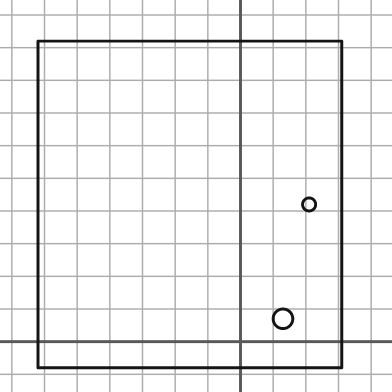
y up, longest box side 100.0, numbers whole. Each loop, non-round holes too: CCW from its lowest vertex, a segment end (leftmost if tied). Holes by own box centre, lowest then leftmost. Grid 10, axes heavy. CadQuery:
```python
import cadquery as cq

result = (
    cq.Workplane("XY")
    .moveTo(-62.0, -8.0)
    .lineTo(31.0, -8.0)
    .lineTo(31.0, 92.0)
    .lineTo(-62.0, 92.0)
    .close()
    .moveTo(13.0, 7.0)
    .circle(3.0)
    .moveTo(21.0, 42.0)
    .circle(2.0)
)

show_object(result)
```